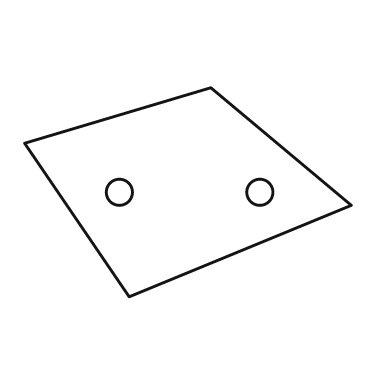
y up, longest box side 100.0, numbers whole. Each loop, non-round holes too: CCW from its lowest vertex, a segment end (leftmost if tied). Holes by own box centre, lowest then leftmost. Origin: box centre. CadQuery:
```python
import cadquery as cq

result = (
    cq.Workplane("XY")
    .moveTo(-18.0, -32.0)
    .lineTo(50.0, -4.0)
    .lineTo(7.0, 32.0)
    .lineTo(-50.0, 15.0)
    .close()
    .moveTo(-21.0, 0.0)
    .circle(4.0)
    .moveTo(22.0, 0.0)
    .circle(4.0)
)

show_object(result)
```